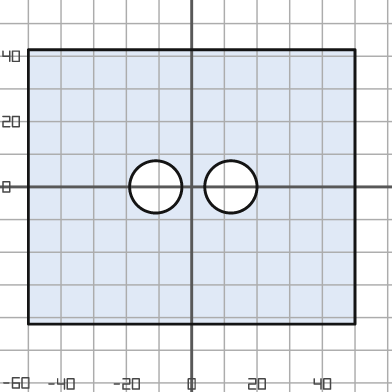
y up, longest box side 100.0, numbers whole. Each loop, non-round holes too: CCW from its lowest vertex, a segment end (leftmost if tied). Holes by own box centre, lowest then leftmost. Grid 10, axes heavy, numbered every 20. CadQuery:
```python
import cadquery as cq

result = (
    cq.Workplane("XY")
    .moveTo(-50.0, -42.0)
    .lineTo(50.0, -42.0)
    .lineTo(50.0, 42.0)
    .lineTo(-50.0, 42.0)
    .close()
    .moveTo(-11.0, 0.0)
    .circle(8.0)
    .moveTo(12.0, 0.0)
    .circle(8.0)
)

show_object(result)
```